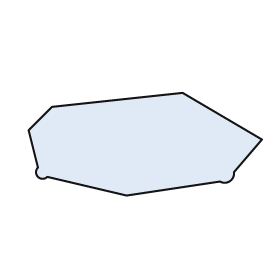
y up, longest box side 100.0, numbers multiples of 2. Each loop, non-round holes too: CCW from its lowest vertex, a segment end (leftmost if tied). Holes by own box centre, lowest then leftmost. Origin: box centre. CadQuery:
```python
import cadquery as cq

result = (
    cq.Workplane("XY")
    .moveTo(-8.0, -22.0)
    .lineTo(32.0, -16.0)
    .threePointArc((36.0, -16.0), (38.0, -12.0))
    .lineTo(50.0, 2.0)
    .lineTo(16.0, 22.0)
    .lineTo(-40.0, 16.0)
    .lineTo(-50.0, 6.0)
    .lineTo(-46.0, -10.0)
    .threePointArc((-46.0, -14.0), (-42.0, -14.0))
    .close()
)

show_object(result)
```